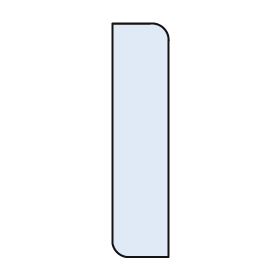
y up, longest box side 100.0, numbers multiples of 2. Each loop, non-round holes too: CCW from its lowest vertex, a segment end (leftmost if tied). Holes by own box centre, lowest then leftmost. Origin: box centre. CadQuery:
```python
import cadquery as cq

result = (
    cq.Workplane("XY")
    .moveTo(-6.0, -50.0)
    .lineTo(12.0, -50.0)
    .lineTo(12.0, 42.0)
    .threePointArc((10.0, 48.0), (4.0, 50.0))
    .lineTo(-12.0, 50.0)
    .lineTo(-12.0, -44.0)
    .threePointArc((-10.0, -48.0), (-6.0, -50.0))
    .close()
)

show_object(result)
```